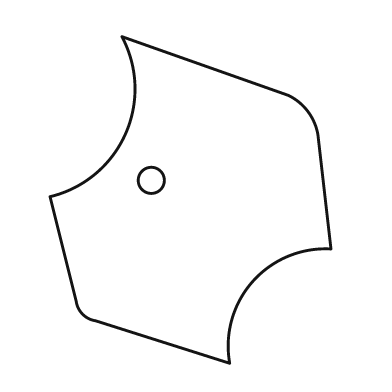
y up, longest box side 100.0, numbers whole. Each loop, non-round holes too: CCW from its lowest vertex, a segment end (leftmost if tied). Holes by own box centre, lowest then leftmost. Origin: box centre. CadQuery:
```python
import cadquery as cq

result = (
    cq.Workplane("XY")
    .moveTo(12.0, -50.0)
    .threePointArc((19.0, -25.0), (43.0, -15.0))
    .lineTo(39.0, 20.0)
    .threePointArc((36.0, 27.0), (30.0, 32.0))
    .lineTo(-21.0, 50.0)
    .threePointArc((-20.0, 20.0), (-43.0, 1.0))
    .lineTo(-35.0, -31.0)
    .threePointArc((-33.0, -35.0), (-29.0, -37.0))
    .close()
    .moveTo(-12.0, 6.0)
    .circle(4.0)
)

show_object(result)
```